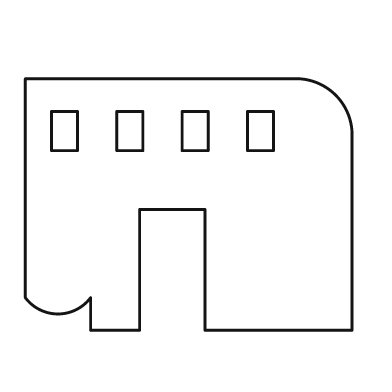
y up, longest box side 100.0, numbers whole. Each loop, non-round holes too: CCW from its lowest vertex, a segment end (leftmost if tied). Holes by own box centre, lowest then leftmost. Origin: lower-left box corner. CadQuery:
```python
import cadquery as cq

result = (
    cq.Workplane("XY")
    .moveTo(20.0, 0.0)
    .lineTo(35.0, 0.0)
    .lineTo(35.0, 37.0)
    .lineTo(55.0, 37.0)
    .lineTo(55.0, 0.0)
    .lineTo(100.0, 0.0)
    .lineTo(100.0, 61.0)
    .threePointArc((95.0, 72.0), (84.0, 77.0))
    .lineTo(0.0, 77.0)
    .lineTo(0.0, 10.0)
    .threePointArc((10.0, 5.0), (20.0, 10.0))
    .close()
    .moveTo(8.0, 55.0)
    .lineTo(16.0, 55.0)
    .lineTo(16.0, 67.0)
    .lineTo(8.0, 67.0)
    .close()
    .moveTo(28.0, 55.0)
    .lineTo(36.0, 55.0)
    .lineTo(36.0, 67.0)
    .lineTo(28.0, 67.0)
    .close()
    .moveTo(48.0, 55.0)
    .lineTo(56.0, 55.0)
    .lineTo(56.0, 67.0)
    .lineTo(48.0, 67.0)
    .close()
    .moveTo(68.0, 55.0)
    .lineTo(76.0, 55.0)
    .lineTo(76.0, 67.0)
    .lineTo(68.0, 67.0)
    .close()
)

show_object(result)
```